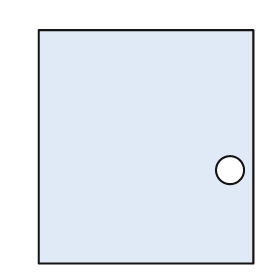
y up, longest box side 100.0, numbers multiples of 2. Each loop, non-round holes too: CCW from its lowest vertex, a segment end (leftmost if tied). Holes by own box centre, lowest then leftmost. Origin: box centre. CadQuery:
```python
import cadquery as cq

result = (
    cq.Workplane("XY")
    .moveTo(-46.0, -50.0)
    .lineTo(46.0, -50.0)
    .lineTo(46.0, 50.0)
    .lineTo(-46.0, 50.0)
    .close()
    .moveTo(36.0, -10.0)
    .circle(6.0)
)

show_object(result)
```